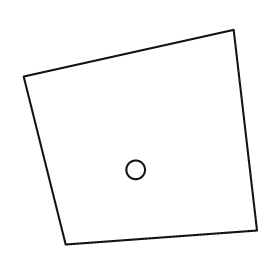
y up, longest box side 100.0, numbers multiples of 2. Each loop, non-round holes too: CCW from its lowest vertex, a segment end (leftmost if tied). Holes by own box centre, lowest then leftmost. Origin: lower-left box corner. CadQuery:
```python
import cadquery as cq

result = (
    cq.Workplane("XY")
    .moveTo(18.0, 0.0)
    .lineTo(100.0, 6.0)
    .lineTo(90.0, 92.0)
    .lineTo(0.0, 72.0)
    .close()
    .moveTo(48.0, 32.0)
    .circle(4.0)
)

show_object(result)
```